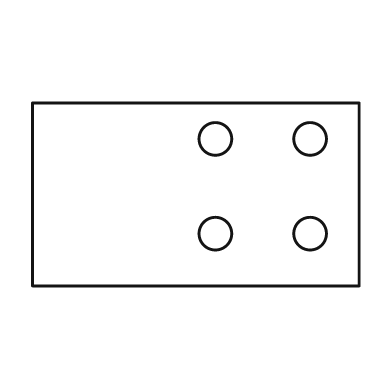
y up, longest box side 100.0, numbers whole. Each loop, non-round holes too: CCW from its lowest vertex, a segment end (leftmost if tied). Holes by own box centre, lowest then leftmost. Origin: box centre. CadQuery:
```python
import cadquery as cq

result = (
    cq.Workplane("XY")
    .moveTo(-50.0, -28.0)
    .lineTo(50.0, -28.0)
    .lineTo(50.0, 28.0)
    .lineTo(-50.0, 28.0)
    .close()
    .moveTo(6.0, -12.0)
    .circle(5.0)
    .moveTo(35.0, -12.0)
    .circle(5.0)
    .moveTo(6.0, 17.0)
    .circle(5.0)
    .moveTo(35.0, 17.0)
    .circle(5.0)
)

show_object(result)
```